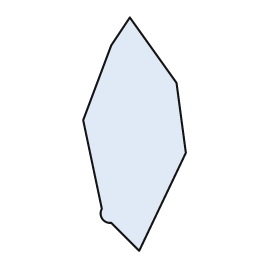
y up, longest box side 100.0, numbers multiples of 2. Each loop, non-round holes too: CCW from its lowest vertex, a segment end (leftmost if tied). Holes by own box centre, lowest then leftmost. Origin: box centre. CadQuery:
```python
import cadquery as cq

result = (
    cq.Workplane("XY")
    .moveTo(2.0, -50.0)
    .lineTo(22.0, -8.0)
    .lineTo(18.0, 22.0)
    .lineTo(-2.0, 50.0)
    .lineTo(-10.0, 38.0)
    .lineTo(-22.0, 6.0)
    .lineTo(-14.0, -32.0)
    .threePointArc((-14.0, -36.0), (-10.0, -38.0))
    .close()
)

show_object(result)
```